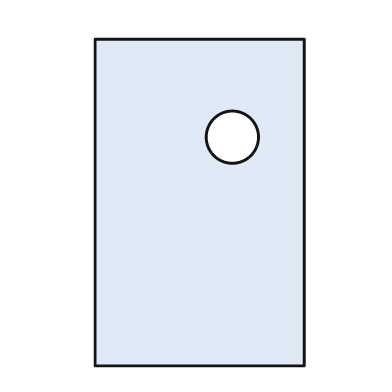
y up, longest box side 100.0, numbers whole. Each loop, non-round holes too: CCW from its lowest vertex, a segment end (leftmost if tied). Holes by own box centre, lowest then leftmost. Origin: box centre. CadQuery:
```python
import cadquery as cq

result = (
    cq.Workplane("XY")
    .moveTo(-32.0, -50.0)
    .lineTo(32.0, -50.0)
    .lineTo(32.0, 50.0)
    .lineTo(-32.0, 50.0)
    .close()
    .moveTo(10.0, 20.0)
    .circle(8.0)
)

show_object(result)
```